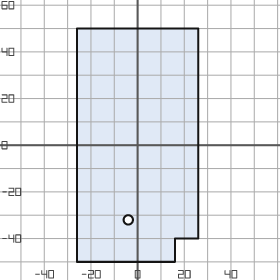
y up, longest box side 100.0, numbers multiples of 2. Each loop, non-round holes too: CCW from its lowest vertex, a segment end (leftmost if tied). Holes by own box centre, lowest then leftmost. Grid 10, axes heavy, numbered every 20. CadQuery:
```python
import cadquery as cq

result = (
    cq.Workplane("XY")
    .moveTo(-26.0, -50.0)
    .lineTo(16.0, -50.0)
    .lineTo(16.0, -40.0)
    .lineTo(26.0, -40.0)
    .lineTo(26.0, 50.0)
    .lineTo(-26.0, 50.0)
    .close()
    .moveTo(-4.0, -32.0)
    .circle(2.0)
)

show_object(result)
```